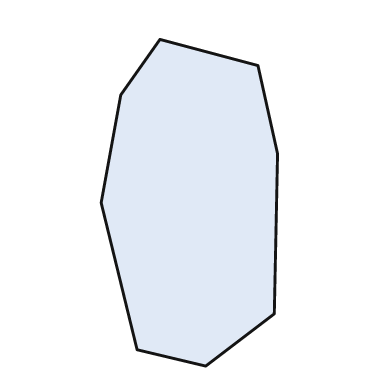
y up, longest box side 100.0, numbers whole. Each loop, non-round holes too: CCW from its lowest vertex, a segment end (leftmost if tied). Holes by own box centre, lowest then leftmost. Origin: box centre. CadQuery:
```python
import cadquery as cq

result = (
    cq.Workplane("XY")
    .moveTo(5.0, -50.0)
    .lineTo(26.0, -34.0)
    .lineTo(27.0, 15.0)
    .lineTo(21.0, 42.0)
    .lineTo(-9.0, 50.0)
    .lineTo(-21.0, 33.0)
    .lineTo(-27.0, 0.0)
    .lineTo(-16.0, -45.0)
    .close()
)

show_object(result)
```